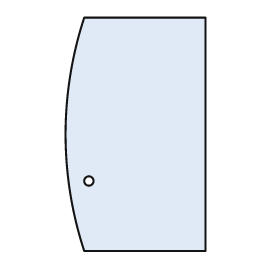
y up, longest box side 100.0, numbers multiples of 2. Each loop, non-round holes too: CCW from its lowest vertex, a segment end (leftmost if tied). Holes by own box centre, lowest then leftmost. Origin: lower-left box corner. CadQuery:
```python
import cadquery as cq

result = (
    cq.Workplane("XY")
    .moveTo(8.0, 0.0)
    .lineTo(60.0, 0.0)
    .lineTo(60.0, 100.0)
    .lineTo(8.0, 100.0)
    .threePointArc((0.0, 50.0), (8.0, 0.0))
    .close()
    .moveTo(10.0, 30.0)
    .circle(2.0)
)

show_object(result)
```